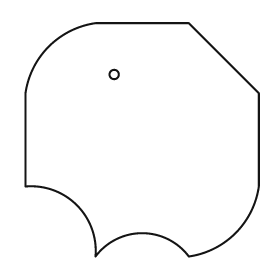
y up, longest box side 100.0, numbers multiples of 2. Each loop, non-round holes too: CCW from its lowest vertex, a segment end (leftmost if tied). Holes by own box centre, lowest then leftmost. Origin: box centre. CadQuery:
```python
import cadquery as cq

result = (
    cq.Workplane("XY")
    .moveTo(-20.0, -50.0)
    .threePointArc((0.0, -40.0), (20.0, -50.0))
    .threePointArc((40.0, -40.0), (50.0, -20.0))
    .lineTo(50.0, 20.0)
    .lineTo(20.0, 50.0)
    .lineTo(-20.0, 50.0)
    .threePointArc((-40.0, 40.0), (-50.0, 20.0))
    .lineTo(-50.0, -20.0)
    .threePointArc((-28.0, -28.0), (-20.0, -50.0))
    .close()
    .moveTo(-12.0, 28.0)
    .circle(2.0)
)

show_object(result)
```